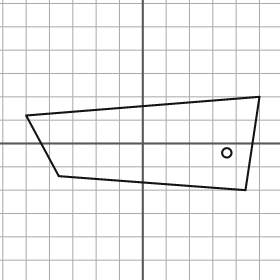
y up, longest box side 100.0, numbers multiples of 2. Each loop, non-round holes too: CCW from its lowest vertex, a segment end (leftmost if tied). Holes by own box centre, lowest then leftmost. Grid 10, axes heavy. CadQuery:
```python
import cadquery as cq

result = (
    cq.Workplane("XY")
    .moveTo(44.0, -20.0)
    .lineTo(50.0, 20.0)
    .lineTo(-50.0, 12.0)
    .lineTo(-36.0, -14.0)
    .close()
    .moveTo(36.0, -4.0)
    .circle(2.0)
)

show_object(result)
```